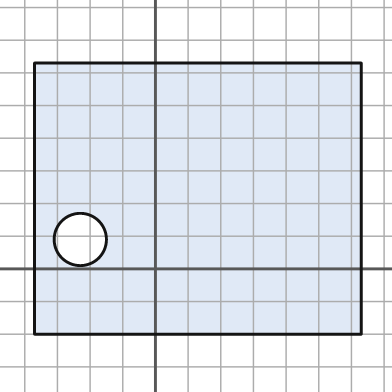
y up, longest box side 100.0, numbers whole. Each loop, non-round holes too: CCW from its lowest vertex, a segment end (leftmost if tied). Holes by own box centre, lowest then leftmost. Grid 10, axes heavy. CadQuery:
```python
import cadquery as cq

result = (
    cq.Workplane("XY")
    .moveTo(-37.0, -20.0)
    .lineTo(63.0, -20.0)
    .lineTo(63.0, 63.0)
    .lineTo(-37.0, 63.0)
    .close()
    .moveTo(-23.0, 9.0)
    .circle(8.0)
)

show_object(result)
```